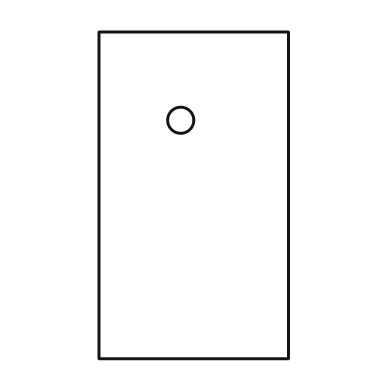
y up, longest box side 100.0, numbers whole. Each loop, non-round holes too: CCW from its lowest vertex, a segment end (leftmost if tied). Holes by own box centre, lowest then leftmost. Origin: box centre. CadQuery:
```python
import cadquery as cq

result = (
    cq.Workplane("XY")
    .moveTo(-29.0, -50.0)
    .lineTo(29.0, -50.0)
    .lineTo(29.0, 50.0)
    .lineTo(-29.0, 50.0)
    .close()
    .moveTo(-4.0, 23.0)
    .circle(4.0)
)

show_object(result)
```